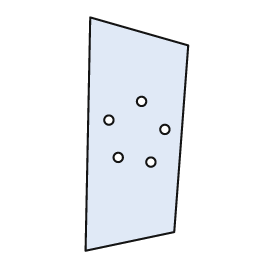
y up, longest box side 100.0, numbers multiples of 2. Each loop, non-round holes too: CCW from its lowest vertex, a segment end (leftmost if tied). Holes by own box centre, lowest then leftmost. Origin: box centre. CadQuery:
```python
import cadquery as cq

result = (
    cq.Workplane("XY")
    .moveTo(-22.0, -50.0)
    .lineTo(16.0, -42.0)
    .lineTo(22.0, 38.0)
    .lineTo(-20.0, 50.0)
    .close()
    .moveTo(6.0, -12.0)
    .circle(2.0)
    .moveTo(-8.0, -10.0)
    .circle(2.0)
    .moveTo(12.0, 2.0)
    .circle(2.0)
    .moveTo(-12.0, 6.0)
    .circle(2.0)
    .moveTo(2.0, 14.0)
    .circle(2.0)
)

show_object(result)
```